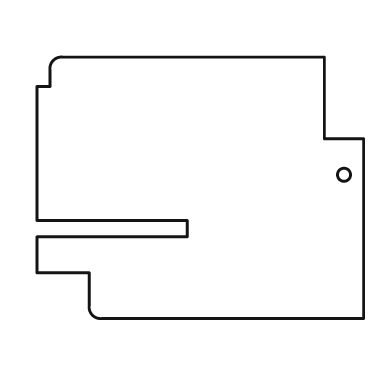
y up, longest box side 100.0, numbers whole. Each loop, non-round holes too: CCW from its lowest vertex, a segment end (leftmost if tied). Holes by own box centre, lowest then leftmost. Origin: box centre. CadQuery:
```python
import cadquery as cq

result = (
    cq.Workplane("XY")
    .moveTo(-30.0, -40.0)
    .lineTo(50.0, -40.0)
    .lineTo(50.0, 15.0)
    .lineTo(38.0, 15.0)
    .lineTo(38.0, 40.0)
    .lineTo(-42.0, 40.0)
    .threePointArc((-45.0, 39.0), (-46.0, 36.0))
    .lineTo(-46.0, 31.0)
    .lineTo(-50.0, 31.0)
    .lineTo(-50.0, -10.0)
    .lineTo(-4.0, -10.0)
    .lineTo(-4.0, -15.0)
    .lineTo(-50.0, -15.0)
    .lineTo(-50.0, -26.0)
    .lineTo(-34.0, -26.0)
    .lineTo(-34.0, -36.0)
    .threePointArc((-33.0, -39.0), (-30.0, -40.0))
    .close()
    .moveTo(44.0, 4.0)
    .circle(2.0)
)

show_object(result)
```